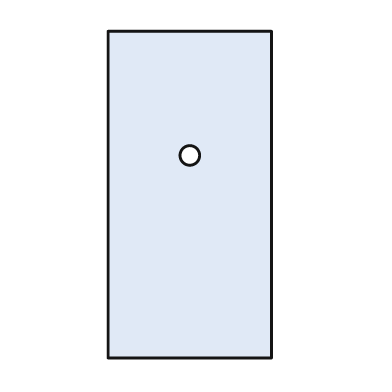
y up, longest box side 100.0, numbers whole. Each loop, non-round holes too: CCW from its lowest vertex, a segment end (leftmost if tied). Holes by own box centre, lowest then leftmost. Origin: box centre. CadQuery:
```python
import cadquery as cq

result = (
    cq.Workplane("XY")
    .moveTo(-25.0, -50.0)
    .lineTo(25.0, -50.0)
    .lineTo(25.0, 50.0)
    .lineTo(-25.0, 50.0)
    .close()
    .moveTo(0.0, 12.0)
    .circle(3.0)
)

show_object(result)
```